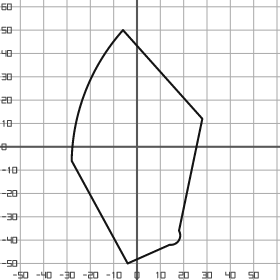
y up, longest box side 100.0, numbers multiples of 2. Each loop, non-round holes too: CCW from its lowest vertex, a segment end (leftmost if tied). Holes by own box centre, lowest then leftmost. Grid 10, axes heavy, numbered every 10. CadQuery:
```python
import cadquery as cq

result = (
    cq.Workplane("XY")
    .moveTo(-4.0, -50.0)
    .lineTo(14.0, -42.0)
    .threePointArc((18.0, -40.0), (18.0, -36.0))
    .lineTo(28.0, 12.0)
    .lineTo(-6.0, 50.0)
    .threePointArc((-22.0, 24.0), (-28.0, -6.0))
    .close()
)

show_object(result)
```